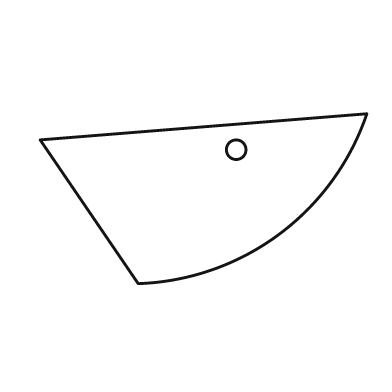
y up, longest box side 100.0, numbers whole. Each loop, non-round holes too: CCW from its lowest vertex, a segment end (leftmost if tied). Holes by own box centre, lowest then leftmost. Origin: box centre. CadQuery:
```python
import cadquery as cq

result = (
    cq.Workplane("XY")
    .moveTo(-20.0, -26.0)
    .threePointArc((23.0, -11.0), (50.0, 26.0))
    .lineTo(-50.0, 18.0)
    .close()
    .moveTo(10.0, 15.0)
    .circle(3.0)
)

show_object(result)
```